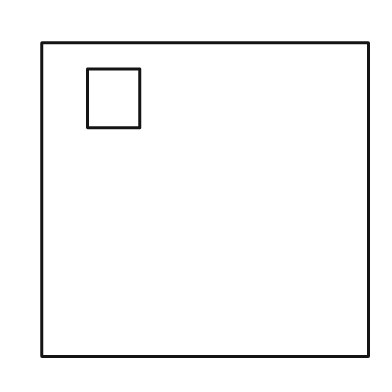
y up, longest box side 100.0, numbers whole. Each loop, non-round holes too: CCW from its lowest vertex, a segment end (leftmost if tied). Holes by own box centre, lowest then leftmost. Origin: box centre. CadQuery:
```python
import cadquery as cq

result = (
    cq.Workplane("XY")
    .moveTo(-50.0, -48.0)
    .lineTo(50.0, -48.0)
    .lineTo(50.0, 48.0)
    .lineTo(-50.0, 48.0)
    .close()
    .moveTo(-36.0, 22.0)
    .lineTo(-20.0, 22.0)
    .lineTo(-20.0, 40.0)
    .lineTo(-36.0, 40.0)
    .close()
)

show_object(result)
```